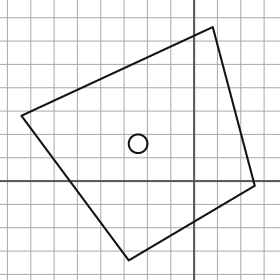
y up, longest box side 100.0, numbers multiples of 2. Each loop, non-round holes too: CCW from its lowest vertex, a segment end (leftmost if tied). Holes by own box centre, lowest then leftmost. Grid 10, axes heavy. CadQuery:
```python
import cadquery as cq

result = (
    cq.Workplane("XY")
    .moveTo(-28.0, -34.0)
    .lineTo(26.0, -2.0)
    .lineTo(8.0, 66.0)
    .lineTo(-74.0, 28.0)
    .close()
    .moveTo(-24.0, 16.0)
    .circle(4.0)
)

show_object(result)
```